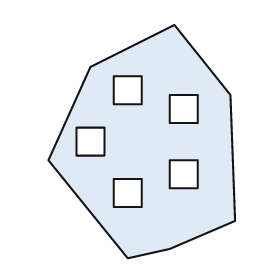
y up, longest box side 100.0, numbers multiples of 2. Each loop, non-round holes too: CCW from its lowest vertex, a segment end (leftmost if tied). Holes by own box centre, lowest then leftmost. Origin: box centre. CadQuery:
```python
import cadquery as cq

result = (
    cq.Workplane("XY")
    .moveTo(-6.0, -50.0)
    .lineTo(12.0, -46.0)
    .lineTo(40.0, -34.0)
    .lineTo(38.0, 20.0)
    .lineTo(14.0, 50.0)
    .lineTo(-22.0, 32.0)
    .lineTo(-40.0, -8.0)
    .close()
    .moveTo(-12.0, -28.0)
    .lineTo(0.0, -28.0)
    .lineTo(0.0, -16.0)
    .lineTo(-12.0, -16.0)
    .close()
    .moveTo(12.0, -20.0)
    .lineTo(24.0, -20.0)
    .lineTo(24.0, -8.0)
    .lineTo(12.0, -8.0)
    .close()
    .moveTo(-28.0, -6.0)
    .lineTo(-16.0, -6.0)
    .lineTo(-16.0, 6.0)
    .lineTo(-28.0, 6.0)
    .close()
    .moveTo(12.0, 8.0)
    .lineTo(24.0, 8.0)
    .lineTo(24.0, 20.0)
    .lineTo(12.0, 20.0)
    .close()
    .moveTo(-12.0, 16.0)
    .lineTo(0.0, 16.0)
    .lineTo(0.0, 28.0)
    .lineTo(-12.0, 28.0)
    .close()
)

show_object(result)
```